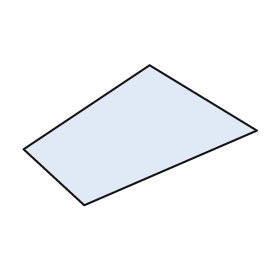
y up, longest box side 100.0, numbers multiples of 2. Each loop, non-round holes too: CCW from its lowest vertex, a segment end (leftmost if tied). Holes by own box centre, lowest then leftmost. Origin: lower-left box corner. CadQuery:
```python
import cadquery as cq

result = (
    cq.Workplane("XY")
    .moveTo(26.0, 0.0)
    .lineTo(100.0, 32.0)
    .lineTo(54.0, 60.0)
    .lineTo(0.0, 24.0)
    .close()
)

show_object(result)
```